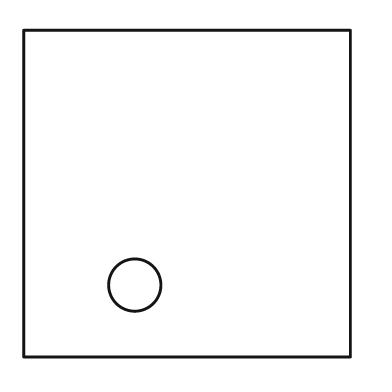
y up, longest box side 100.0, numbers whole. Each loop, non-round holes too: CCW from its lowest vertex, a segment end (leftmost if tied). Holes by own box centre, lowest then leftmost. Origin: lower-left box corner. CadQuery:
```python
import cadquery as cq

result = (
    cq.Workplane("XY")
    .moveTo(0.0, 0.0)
    .lineTo(100.0, 0.0)
    .lineTo(100.0, 100.0)
    .lineTo(0.0, 100.0)
    .close()
    .moveTo(34.0, 22.0)
    .circle(8.0)
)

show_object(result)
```